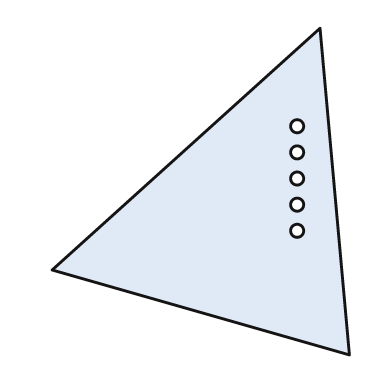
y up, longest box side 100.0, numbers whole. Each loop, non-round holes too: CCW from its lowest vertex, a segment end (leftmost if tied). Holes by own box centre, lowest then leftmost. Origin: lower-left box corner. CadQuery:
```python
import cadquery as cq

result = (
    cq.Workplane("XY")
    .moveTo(91.0, 0.0)
    .lineTo(82.0, 100.0)
    .lineTo(0.0, 26.0)
    .close()
    .moveTo(75.0, 38.0)
    .circle(2.0)
    .moveTo(75.0, 46.0)
    .circle(2.0)
    .moveTo(75.0, 54.0)
    .circle(2.0)
    .moveTo(75.0, 62.0)
    .circle(2.0)
    .moveTo(75.0, 70.0)
    .circle(2.0)
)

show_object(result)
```